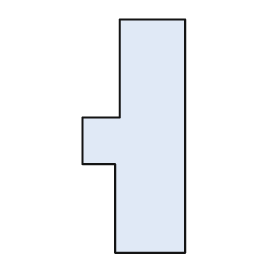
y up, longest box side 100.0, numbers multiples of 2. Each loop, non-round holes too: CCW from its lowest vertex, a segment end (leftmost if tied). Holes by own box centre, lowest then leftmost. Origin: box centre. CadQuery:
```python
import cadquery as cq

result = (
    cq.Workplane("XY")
    .moveTo(-8.0, -50.0)
    .lineTo(22.0, -50.0)
    .lineTo(22.0, 50.0)
    .lineTo(-6.0, 50.0)
    .lineTo(-6.0, 8.0)
    .lineTo(-22.0, 8.0)
    .lineTo(-22.0, -12.0)
    .lineTo(-8.0, -12.0)
    .close()
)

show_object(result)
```